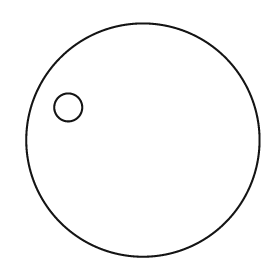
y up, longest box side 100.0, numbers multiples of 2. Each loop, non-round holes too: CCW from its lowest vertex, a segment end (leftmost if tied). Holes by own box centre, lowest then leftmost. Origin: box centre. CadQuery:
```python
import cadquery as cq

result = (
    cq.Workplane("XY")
    .moveTo(0.0, 0.0)
    .circle(50.0)
    .moveTo(-32.0, 14.0)
    .circle(6.0)
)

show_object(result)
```